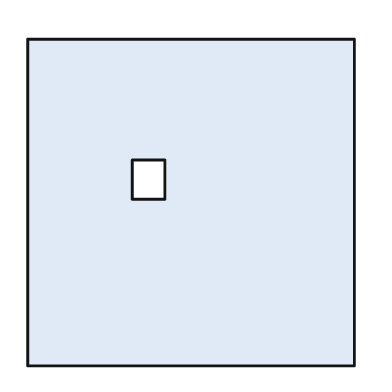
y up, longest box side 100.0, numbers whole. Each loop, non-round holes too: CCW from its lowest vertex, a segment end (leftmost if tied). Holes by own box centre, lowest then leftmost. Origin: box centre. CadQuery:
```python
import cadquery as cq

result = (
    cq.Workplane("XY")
    .moveTo(-50.0, -50.0)
    .lineTo(50.0, -50.0)
    .lineTo(50.0, 50.0)
    .lineTo(-50.0, 50.0)
    .close()
    .moveTo(-18.0, 1.0)
    .lineTo(-8.0, 1.0)
    .lineTo(-8.0, 13.0)
    .lineTo(-18.0, 13.0)
    .close()
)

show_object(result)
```